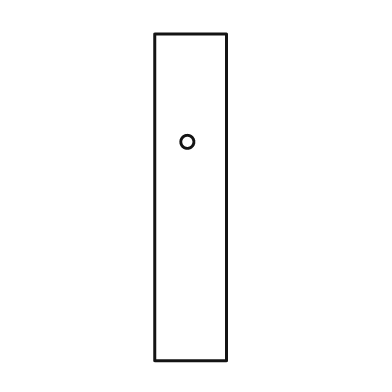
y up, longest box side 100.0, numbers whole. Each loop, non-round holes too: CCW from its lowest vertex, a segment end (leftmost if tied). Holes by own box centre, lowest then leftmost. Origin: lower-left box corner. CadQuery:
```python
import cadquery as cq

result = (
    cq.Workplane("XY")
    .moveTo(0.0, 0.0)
    .lineTo(22.0, 0.0)
    .lineTo(22.0, 100.0)
    .lineTo(0.0, 100.0)
    .close()
    .moveTo(10.0, 67.0)
    .circle(2.0)
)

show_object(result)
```